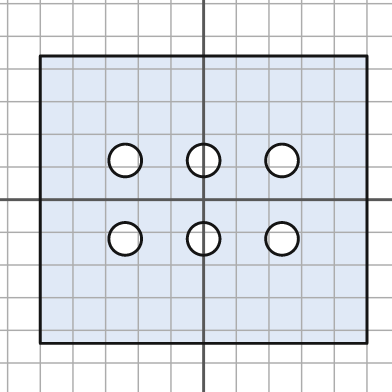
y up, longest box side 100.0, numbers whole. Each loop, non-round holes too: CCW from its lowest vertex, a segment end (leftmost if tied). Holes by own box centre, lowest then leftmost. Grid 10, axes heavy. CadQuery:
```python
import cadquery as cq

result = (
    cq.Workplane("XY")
    .moveTo(-50.0, -44.0)
    .lineTo(50.0, -44.0)
    .lineTo(50.0, 44.0)
    .lineTo(-50.0, 44.0)
    .close()
    .moveTo(-24.0, -12.0)
    .circle(5.0)
    .moveTo(0.0, -12.0)
    .circle(5.0)
    .moveTo(24.0, -12.0)
    .circle(5.0)
    .moveTo(-24.0, 12.0)
    .circle(5.0)
    .moveTo(0.0, 12.0)
    .circle(5.0)
    .moveTo(24.0, 12.0)
    .circle(5.0)
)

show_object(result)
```